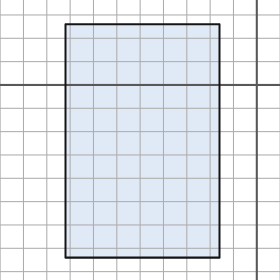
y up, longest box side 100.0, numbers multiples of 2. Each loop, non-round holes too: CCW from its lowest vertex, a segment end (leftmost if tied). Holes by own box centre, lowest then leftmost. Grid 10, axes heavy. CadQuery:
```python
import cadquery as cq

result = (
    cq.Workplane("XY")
    .moveTo(-82.0, -74.0)
    .lineTo(-16.0, -74.0)
    .lineTo(-16.0, 26.0)
    .lineTo(-82.0, 26.0)
    .close()
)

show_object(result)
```